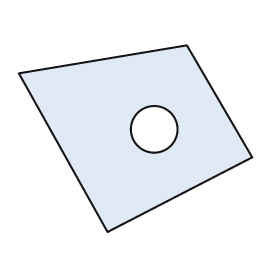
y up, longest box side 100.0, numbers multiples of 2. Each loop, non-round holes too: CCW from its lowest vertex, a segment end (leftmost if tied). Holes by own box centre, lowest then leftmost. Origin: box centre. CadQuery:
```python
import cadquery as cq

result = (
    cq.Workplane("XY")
    .moveTo(-12.0, -40.0)
    .lineTo(50.0, -8.0)
    .lineTo(22.0, 40.0)
    .lineTo(-50.0, 28.0)
    .close()
    .moveTo(8.0, 4.0)
    .circle(10.0)
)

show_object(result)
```